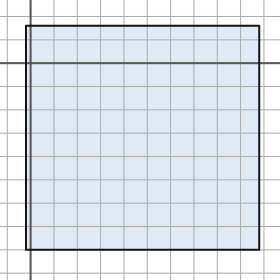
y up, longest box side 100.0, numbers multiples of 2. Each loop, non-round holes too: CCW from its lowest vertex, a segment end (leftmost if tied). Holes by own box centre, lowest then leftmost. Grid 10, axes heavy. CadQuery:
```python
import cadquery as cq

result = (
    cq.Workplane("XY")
    .moveTo(-2.0, -80.0)
    .lineTo(98.0, -80.0)
    .lineTo(98.0, 16.0)
    .lineTo(-2.0, 16.0)
    .close()
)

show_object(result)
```